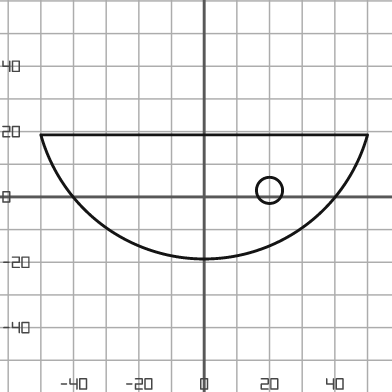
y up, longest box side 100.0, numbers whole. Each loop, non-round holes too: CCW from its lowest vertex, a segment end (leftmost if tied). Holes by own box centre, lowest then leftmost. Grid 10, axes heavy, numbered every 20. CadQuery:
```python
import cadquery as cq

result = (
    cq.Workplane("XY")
    .moveTo(-50.0, 19.0)
    .threePointArc((0.0, -19.0), (50.0, 19.0))
    .close()
    .moveTo(20.0, 2.0)
    .circle(4.0)
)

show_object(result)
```